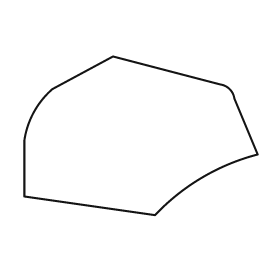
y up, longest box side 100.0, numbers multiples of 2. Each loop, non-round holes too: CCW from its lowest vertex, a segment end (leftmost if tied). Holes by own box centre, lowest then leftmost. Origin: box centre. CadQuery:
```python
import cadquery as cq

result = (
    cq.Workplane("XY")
    .moveTo(6.0, -34.0)
    .threePointArc((26.0, -18.0), (50.0, -8.0))
    .lineTo(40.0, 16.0)
    .threePointArc((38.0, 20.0), (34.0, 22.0))
    .lineTo(-12.0, 34.0)
    .lineTo(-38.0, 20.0)
    .threePointArc((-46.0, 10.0), (-50.0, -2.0))
    .lineTo(-50.0, -26.0)
    .close()
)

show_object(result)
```